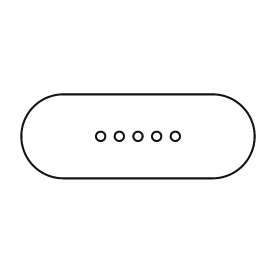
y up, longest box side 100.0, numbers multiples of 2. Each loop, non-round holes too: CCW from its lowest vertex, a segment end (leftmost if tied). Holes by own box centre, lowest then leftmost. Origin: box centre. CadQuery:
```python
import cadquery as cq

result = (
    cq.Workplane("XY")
    .moveTo(-32.0, -18.0)
    .lineTo(32.0, -18.0)
    .threePointArc((50.0, 0.0), (32.0, 18.0))
    .lineTo(-32.0, 18.0)
    .threePointArc((-50.0, 0.0), (-32.0, -18.0))
    .close()
    .moveTo(-16.0, 0.0)
    .circle(2.0)
    .moveTo(-8.0, 0.0)
    .circle(2.0)
    .moveTo(0.0, 0.0)
    .circle(2.0)
    .moveTo(8.0, 0.0)
    .circle(2.0)
    .moveTo(16.0, 0.0)
    .circle(2.0)
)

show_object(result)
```